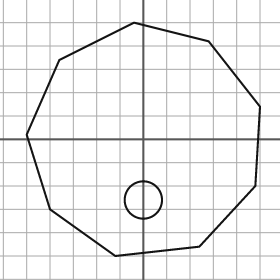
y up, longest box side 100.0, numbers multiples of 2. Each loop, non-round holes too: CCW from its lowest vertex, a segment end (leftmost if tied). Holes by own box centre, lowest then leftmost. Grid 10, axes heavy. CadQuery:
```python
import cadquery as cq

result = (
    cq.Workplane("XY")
    .moveTo(-12.0, -50.0)
    .lineTo(24.0, -46.0)
    .lineTo(48.0, -20.0)
    .lineTo(50.0, 14.0)
    .lineTo(28.0, 42.0)
    .lineTo(-4.0, 50.0)
    .lineTo(-36.0, 34.0)
    .lineTo(-50.0, 2.0)
    .lineTo(-40.0, -30.0)
    .close()
    .moveTo(0.0, -26.0)
    .circle(8.0)
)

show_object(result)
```